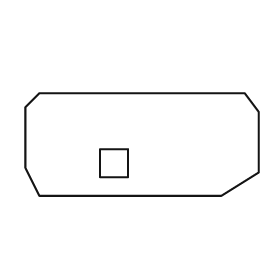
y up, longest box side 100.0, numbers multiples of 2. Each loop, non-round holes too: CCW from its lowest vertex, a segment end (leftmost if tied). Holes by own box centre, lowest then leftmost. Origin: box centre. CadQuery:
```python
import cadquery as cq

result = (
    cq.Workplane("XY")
    .moveTo(-44.0, -22.0)
    .lineTo(34.0, -22.0)
    .lineTo(50.0, -12.0)
    .lineTo(50.0, 14.0)
    .lineTo(44.0, 22.0)
    .lineTo(-44.0, 22.0)
    .lineTo(-50.0, 16.0)
    .lineTo(-50.0, -10.0)
    .close()
    .moveTo(-18.0, -14.0)
    .lineTo(-6.0, -14.0)
    .lineTo(-6.0, -2.0)
    .lineTo(-18.0, -2.0)
    .close()
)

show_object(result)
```